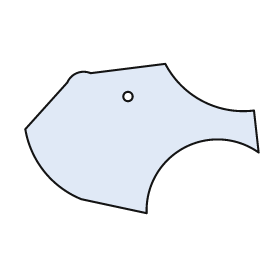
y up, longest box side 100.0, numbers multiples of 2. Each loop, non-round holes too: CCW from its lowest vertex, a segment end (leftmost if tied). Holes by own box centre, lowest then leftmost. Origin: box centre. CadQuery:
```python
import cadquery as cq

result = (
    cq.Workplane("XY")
    .moveTo(2.0, -32.0)
    .threePointArc((18.0, -4.0), (50.0, -6.0))
    .lineTo(48.0, 12.0)
    .threePointArc((26.0, 16.0), (10.0, 32.0))
    .lineTo(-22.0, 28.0)
    .threePointArc((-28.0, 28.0), (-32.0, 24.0))
    .lineTo(-50.0, 4.0)
    .threePointArc((-42.0, -14.0), (-26.0, -26.0))
    .close()
    .moveTo(-6.0, 18.0)
    .circle(2.0)
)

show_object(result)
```